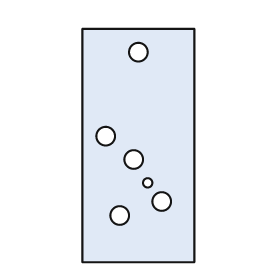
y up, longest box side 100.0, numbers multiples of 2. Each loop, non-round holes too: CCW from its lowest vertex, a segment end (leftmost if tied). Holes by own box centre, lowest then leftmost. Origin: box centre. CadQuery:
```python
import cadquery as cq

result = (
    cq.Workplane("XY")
    .moveTo(-24.0, -50.0)
    .lineTo(24.0, -50.0)
    .lineTo(24.0, 50.0)
    .lineTo(-24.0, 50.0)
    .close()
    .moveTo(-8.0, -30.0)
    .circle(4.0)
    .moveTo(10.0, -24.0)
    .circle(4.0)
    .moveTo(4.0, -16.0)
    .circle(2.0)
    .moveTo(-2.0, -6.0)
    .circle(4.0)
    .moveTo(-14.0, 4.0)
    .circle(4.0)
    .moveTo(0.0, 40.0)
    .circle(4.0)
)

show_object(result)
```